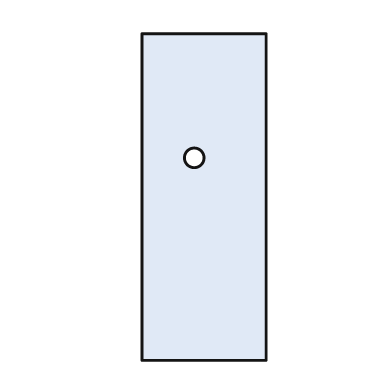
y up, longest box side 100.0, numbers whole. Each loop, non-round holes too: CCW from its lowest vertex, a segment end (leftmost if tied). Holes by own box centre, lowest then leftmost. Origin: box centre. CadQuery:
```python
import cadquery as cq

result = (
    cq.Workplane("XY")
    .moveTo(-19.0, -50.0)
    .lineTo(19.0, -50.0)
    .lineTo(19.0, 50.0)
    .lineTo(-19.0, 50.0)
    .close()
    .moveTo(-3.0, 12.0)
    .circle(3.0)
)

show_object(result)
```